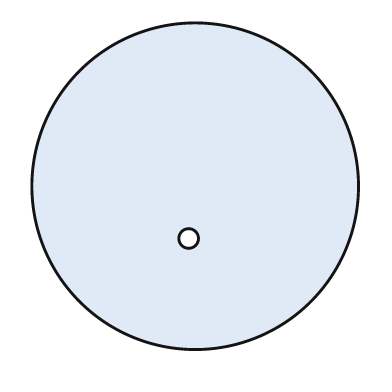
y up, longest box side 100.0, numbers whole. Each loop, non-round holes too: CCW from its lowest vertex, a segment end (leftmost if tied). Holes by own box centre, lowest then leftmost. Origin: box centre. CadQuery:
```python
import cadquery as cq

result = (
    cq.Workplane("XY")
    .moveTo(0.0, 0.0)
    .circle(50.0)
    .moveTo(-2.0, -16.0)
    .circle(3.0)
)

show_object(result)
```